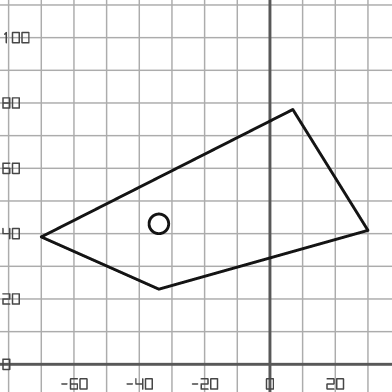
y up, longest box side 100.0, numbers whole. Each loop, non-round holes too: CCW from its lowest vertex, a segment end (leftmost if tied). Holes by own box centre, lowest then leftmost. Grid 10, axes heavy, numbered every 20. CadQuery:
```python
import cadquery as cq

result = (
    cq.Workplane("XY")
    .moveTo(-34.0, 23.0)
    .lineTo(30.0, 41.0)
    .lineTo(7.0, 78.0)
    .lineTo(-70.0, 39.0)
    .close()
    .moveTo(-34.0, 43.0)
    .circle(3.0)
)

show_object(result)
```